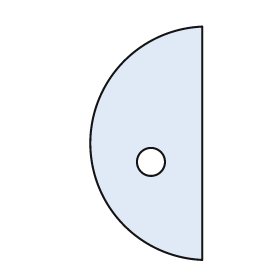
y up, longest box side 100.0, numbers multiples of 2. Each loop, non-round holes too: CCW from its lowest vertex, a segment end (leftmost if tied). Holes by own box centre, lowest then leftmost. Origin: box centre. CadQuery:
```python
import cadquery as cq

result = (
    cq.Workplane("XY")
    .moveTo(24.0, -50.0)
    .lineTo(24.0, 50.0)
    .threePointArc((-24.0, 0.0), (24.0, -50.0))
    .close()
    .moveTo(2.0, -8.0)
    .circle(6.0)
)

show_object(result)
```